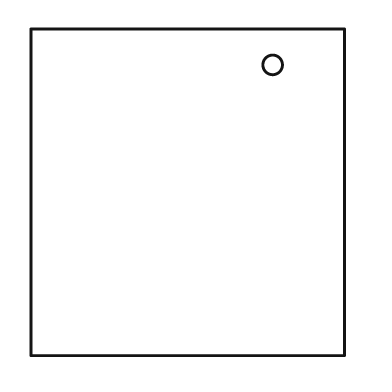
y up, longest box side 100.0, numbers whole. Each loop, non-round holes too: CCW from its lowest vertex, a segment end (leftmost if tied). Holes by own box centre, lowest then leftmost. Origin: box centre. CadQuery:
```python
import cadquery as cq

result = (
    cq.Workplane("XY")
    .moveTo(-48.0, -50.0)
    .lineTo(48.0, -50.0)
    .lineTo(48.0, 50.0)
    .lineTo(-48.0, 50.0)
    .close()
    .moveTo(26.0, 39.0)
    .circle(3.0)
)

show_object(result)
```